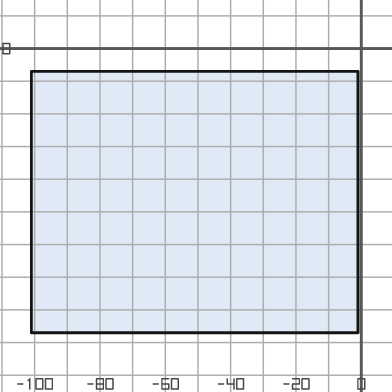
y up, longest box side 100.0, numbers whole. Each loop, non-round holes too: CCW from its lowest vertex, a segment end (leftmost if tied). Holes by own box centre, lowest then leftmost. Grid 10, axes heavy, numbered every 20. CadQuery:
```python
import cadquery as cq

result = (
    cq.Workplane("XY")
    .moveTo(-101.0, -87.0)
    .lineTo(-1.0, -87.0)
    .lineTo(-1.0, -7.0)
    .lineTo(-101.0, -7.0)
    .close()
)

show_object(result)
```